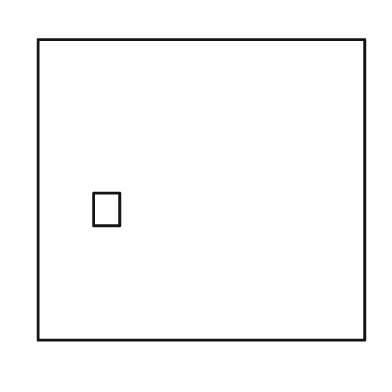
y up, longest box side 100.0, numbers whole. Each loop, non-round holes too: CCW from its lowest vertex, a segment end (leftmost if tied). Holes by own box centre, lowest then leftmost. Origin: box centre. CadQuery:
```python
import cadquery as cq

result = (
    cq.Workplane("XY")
    .moveTo(-50.0, -46.0)
    .lineTo(50.0, -46.0)
    .lineTo(50.0, 46.0)
    .lineTo(-50.0, 46.0)
    .close()
    .moveTo(-33.0, -11.0)
    .lineTo(-25.0, -11.0)
    .lineTo(-25.0, -1.0)
    .lineTo(-33.0, -1.0)
    .close()
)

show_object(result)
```